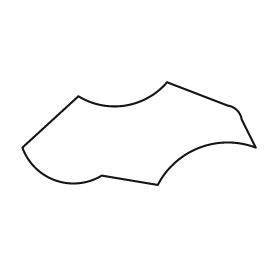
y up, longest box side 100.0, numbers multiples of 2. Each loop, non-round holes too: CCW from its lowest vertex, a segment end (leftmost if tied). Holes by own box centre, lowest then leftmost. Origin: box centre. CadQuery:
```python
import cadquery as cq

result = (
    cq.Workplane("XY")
    .moveTo(8.0, -22.0)
    .threePointArc((26.0, -6.0), (50.0, -6.0))
    .lineTo(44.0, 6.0)
    .threePointArc((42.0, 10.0), (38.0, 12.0))
    .lineTo(12.0, 22.0)
    .threePointArc((-6.0, 12.0), (-26.0, 16.0))
    .lineTo(-50.0, -6.0)
    .threePointArc((-36.0, -20.0), (-16.0, -18.0))
    .close()
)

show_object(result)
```